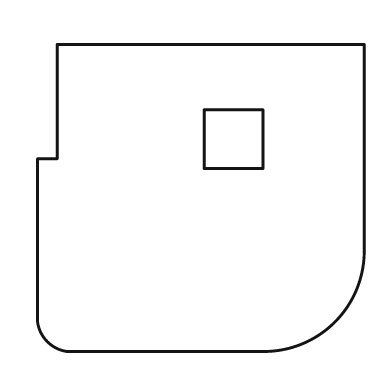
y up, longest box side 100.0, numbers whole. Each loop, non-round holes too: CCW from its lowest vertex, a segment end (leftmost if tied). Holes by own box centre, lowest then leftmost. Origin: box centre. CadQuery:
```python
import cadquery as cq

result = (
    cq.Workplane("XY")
    .moveTo(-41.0, -47.0)
    .lineTo(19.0, -47.0)
    .threePointArc((41.0, -38.0), (50.0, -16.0))
    .lineTo(50.0, 47.0)
    .lineTo(-44.0, 47.0)
    .lineTo(-44.0, 12.0)
    .lineTo(-50.0, 12.0)
    .lineTo(-50.0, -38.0)
    .threePointArc((-47.0, -44.0), (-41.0, -47.0))
    .close()
    .moveTo(1.0, 9.0)
    .lineTo(19.0, 9.0)
    .lineTo(19.0, 27.0)
    .lineTo(1.0, 27.0)
    .close()
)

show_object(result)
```